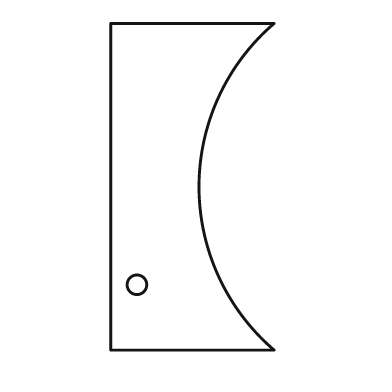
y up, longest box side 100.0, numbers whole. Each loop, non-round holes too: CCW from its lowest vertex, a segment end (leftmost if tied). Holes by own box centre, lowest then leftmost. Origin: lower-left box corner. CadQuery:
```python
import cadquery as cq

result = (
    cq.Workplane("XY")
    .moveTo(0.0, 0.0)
    .lineTo(50.0, 0.0)
    .threePointArc((27.0, 50.0), (50.0, 100.0))
    .lineTo(0.0, 100.0)
    .close()
    .moveTo(8.0, 20.0)
    .circle(3.0)
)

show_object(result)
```